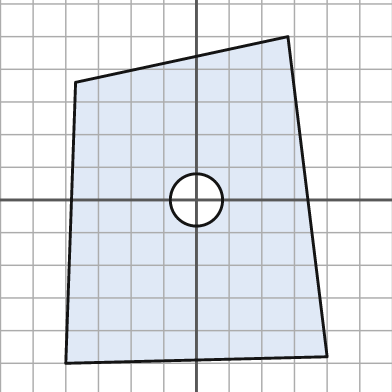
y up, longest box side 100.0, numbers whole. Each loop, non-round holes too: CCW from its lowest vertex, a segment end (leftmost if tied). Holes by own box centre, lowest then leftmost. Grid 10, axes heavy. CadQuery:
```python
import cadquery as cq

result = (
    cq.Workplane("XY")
    .moveTo(-40.0, -50.0)
    .lineTo(40.0, -48.0)
    .lineTo(28.0, 50.0)
    .lineTo(-37.0, 36.0)
    .close()
    .moveTo(0.0, 0.0)
    .circle(8.0)
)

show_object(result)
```